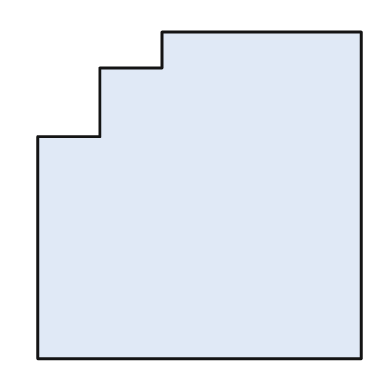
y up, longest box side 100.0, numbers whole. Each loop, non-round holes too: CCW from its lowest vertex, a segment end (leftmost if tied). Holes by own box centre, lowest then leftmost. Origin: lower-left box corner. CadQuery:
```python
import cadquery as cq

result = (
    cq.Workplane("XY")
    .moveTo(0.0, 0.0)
    .lineTo(99.0, 0.0)
    .lineTo(99.0, 100.0)
    .lineTo(38.0, 100.0)
    .lineTo(38.0, 89.0)
    .lineTo(19.0, 89.0)
    .lineTo(19.0, 68.0)
    .lineTo(0.0, 68.0)
    .close()
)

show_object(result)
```